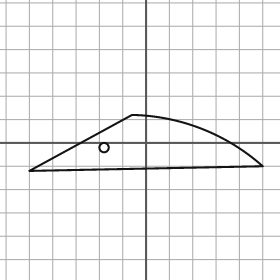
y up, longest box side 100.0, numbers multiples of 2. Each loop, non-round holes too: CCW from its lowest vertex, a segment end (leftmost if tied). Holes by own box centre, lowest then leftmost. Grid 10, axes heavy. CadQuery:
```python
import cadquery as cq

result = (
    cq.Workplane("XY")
    .moveTo(-50.0, -12.0)
    .lineTo(50.0, -10.0)
    .threePointArc((24.0, 6.0), (-6.0, 12.0))
    .close()
    .moveTo(-18.0, -2.0)
    .circle(2.0)
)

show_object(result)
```